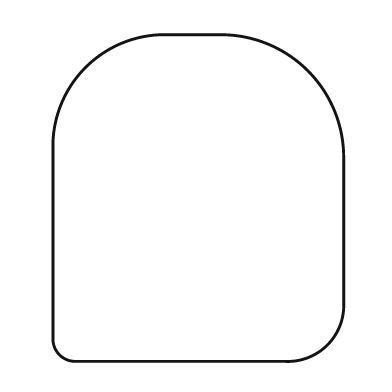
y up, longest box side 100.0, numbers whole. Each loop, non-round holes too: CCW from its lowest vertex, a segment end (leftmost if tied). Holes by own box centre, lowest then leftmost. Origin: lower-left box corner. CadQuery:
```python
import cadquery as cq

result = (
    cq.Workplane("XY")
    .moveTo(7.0, 0.0)
    .lineTo(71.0, 0.0)
    .threePointArc((84.0, 5.0), (89.0, 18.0))
    .lineTo(89.0, 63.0)
    .threePointArc((78.0, 89.0), (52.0, 100.0))
    .lineTo(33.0, 100.0)
    .threePointArc((10.0, 90.0), (0.0, 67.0))
    .lineTo(0.0, 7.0)
    .threePointArc((2.0, 2.0), (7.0, 0.0))
    .close()
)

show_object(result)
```